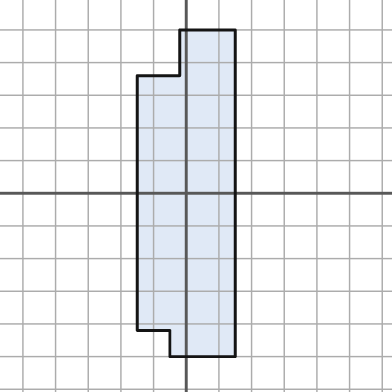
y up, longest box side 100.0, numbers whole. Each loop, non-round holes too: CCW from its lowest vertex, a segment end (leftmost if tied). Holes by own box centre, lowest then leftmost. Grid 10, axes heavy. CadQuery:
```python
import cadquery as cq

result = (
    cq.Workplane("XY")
    .moveTo(-5.0, -50.0)
    .lineTo(15.0, -50.0)
    .lineTo(15.0, 50.0)
    .lineTo(-2.0, 50.0)
    .lineTo(-2.0, 36.0)
    .lineTo(-15.0, 36.0)
    .lineTo(-15.0, -42.0)
    .lineTo(-5.0, -42.0)
    .close()
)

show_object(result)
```